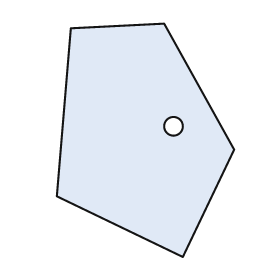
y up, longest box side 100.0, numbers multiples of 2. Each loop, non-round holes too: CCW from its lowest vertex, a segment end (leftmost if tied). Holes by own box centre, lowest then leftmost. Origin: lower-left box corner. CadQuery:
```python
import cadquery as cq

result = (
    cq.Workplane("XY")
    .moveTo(54.0, 0.0)
    .lineTo(76.0, 46.0)
    .lineTo(46.0, 100.0)
    .lineTo(6.0, 98.0)
    .lineTo(0.0, 26.0)
    .close()
    .moveTo(50.0, 56.0)
    .circle(4.0)
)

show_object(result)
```